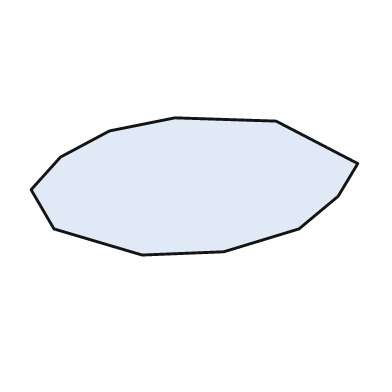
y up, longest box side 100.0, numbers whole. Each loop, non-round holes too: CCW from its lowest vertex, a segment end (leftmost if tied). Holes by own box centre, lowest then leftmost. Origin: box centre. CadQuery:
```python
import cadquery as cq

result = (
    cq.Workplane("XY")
    .moveTo(-16.0, -21.0)
    .lineTo(9.0, -20.0)
    .lineTo(32.0, -13.0)
    .lineTo(44.0, -3.0)
    .lineTo(50.0, 7.0)
    .lineTo(25.0, 20.0)
    .lineTo(-6.0, 21.0)
    .lineTo(-26.0, 17.0)
    .lineTo(-41.0, 9.0)
    .lineTo(-50.0, -1.0)
    .lineTo(-43.0, -13.0)
    .close()
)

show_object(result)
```